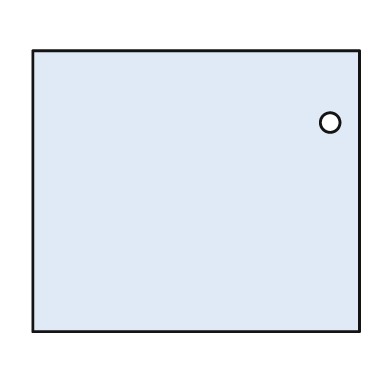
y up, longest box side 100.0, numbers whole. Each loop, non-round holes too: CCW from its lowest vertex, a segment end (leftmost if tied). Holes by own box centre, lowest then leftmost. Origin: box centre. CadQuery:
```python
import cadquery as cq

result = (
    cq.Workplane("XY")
    .moveTo(-50.0, -43.0)
    .lineTo(50.0, -43.0)
    .lineTo(50.0, 43.0)
    .lineTo(-50.0, 43.0)
    .close()
    .moveTo(41.0, 21.0)
    .circle(3.0)
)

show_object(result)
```